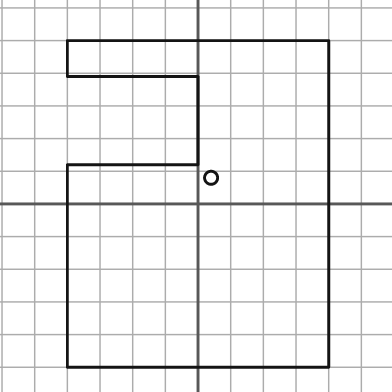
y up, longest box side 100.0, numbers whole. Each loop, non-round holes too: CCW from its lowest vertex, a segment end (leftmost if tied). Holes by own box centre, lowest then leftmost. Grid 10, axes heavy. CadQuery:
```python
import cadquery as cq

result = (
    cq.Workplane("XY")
    .moveTo(-40.0, -50.0)
    .lineTo(40.0, -50.0)
    .lineTo(40.0, 50.0)
    .lineTo(-40.0, 50.0)
    .lineTo(-40.0, 39.0)
    .lineTo(0.0, 39.0)
    .lineTo(0.0, 12.0)
    .lineTo(-40.0, 12.0)
    .close()
    .moveTo(4.0, 8.0)
    .circle(2.0)
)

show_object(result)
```